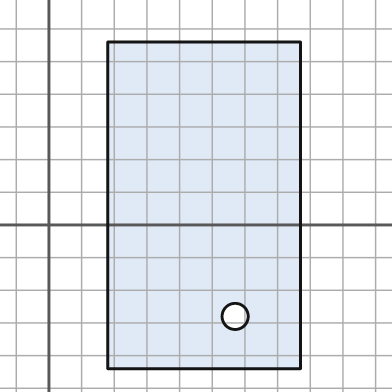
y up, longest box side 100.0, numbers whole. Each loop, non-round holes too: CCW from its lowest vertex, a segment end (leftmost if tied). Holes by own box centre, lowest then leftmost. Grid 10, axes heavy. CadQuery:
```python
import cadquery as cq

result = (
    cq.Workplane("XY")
    .moveTo(18.0, -44.0)
    .lineTo(77.0, -44.0)
    .lineTo(77.0, 56.0)
    .lineTo(18.0, 56.0)
    .close()
    .moveTo(57.0, -28.0)
    .circle(4.0)
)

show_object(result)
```